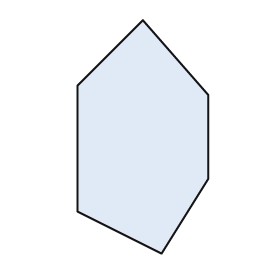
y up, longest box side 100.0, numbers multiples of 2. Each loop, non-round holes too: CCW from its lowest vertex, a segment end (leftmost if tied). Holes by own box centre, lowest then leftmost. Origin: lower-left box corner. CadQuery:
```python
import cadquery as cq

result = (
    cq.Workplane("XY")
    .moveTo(36.0, 0.0)
    .lineTo(56.0, 32.0)
    .lineTo(56.0, 68.0)
    .lineTo(28.0, 100.0)
    .lineTo(0.0, 72.0)
    .lineTo(0.0, 18.0)
    .close()
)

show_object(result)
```